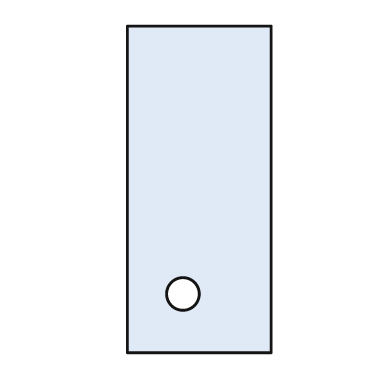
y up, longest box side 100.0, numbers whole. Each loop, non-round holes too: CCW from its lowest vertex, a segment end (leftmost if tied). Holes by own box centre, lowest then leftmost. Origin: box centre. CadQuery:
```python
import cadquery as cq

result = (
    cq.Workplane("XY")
    .moveTo(-22.0, -50.0)
    .lineTo(22.0, -50.0)
    .lineTo(22.0, 50.0)
    .lineTo(-22.0, 50.0)
    .close()
    .moveTo(-5.0, -32.0)
    .circle(5.0)
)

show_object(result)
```